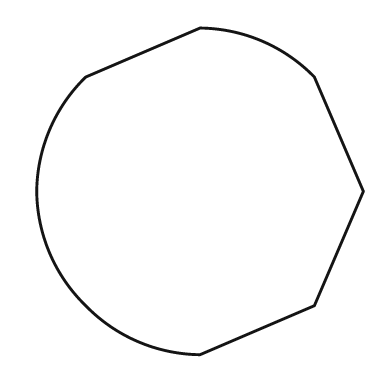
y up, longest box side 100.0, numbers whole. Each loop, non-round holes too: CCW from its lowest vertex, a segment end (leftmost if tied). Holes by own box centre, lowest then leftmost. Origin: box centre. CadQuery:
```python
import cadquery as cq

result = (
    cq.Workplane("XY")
    .moveTo(0.0, -50.0)
    .lineTo(35.0, -35.0)
    .lineTo(50.0, 0.0)
    .lineTo(35.0, 35.0)
    .threePointArc((19.0, 46.0), (0.0, 50.0))
    .lineTo(-35.0, 35.0)
    .threePointArc((-46.0, 19.0), (-50.0, 0.0))
    .threePointArc((-46.0, -19.0), (-35.0, -35.0))
    .threePointArc((-19.0, -46.0), (0.0, -50.0))
    .close()
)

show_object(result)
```